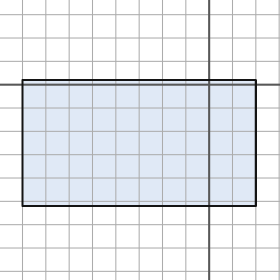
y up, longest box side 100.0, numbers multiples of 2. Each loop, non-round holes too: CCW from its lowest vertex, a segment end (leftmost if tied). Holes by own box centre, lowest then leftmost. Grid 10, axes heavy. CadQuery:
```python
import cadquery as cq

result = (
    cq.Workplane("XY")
    .moveTo(-80.0, -52.0)
    .lineTo(20.0, -52.0)
    .lineTo(20.0, 2.0)
    .lineTo(-80.0, 2.0)
    .close()
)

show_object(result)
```